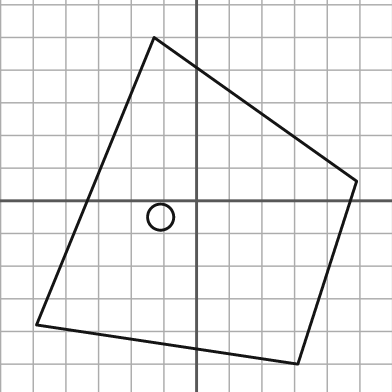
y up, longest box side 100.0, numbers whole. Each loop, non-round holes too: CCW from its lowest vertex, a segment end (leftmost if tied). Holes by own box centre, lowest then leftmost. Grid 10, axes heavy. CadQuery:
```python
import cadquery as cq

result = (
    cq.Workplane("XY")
    .moveTo(31.0, -50.0)
    .lineTo(49.0, 6.0)
    .lineTo(-13.0, 50.0)
    .lineTo(-49.0, -38.0)
    .close()
    .moveTo(-11.0, -5.0)
    .circle(4.0)
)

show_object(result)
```